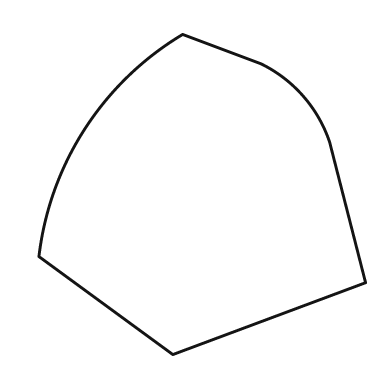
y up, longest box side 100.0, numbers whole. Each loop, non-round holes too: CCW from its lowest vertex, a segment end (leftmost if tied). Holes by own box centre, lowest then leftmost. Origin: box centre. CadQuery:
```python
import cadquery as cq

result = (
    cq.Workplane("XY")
    .moveTo(-9.0, -49.0)
    .lineTo(50.0, -27.0)
    .lineTo(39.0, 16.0)
    .threePointArc((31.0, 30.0), (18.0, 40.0))
    .lineTo(-6.0, 49.0)
    .threePointArc((-36.0, 20.0), (-50.0, -19.0))
    .close()
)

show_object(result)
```